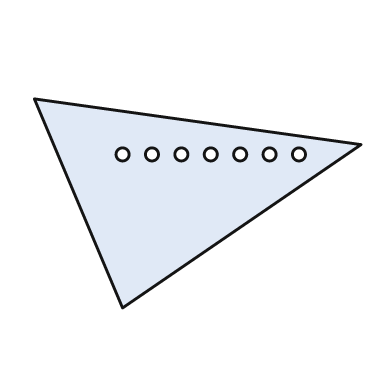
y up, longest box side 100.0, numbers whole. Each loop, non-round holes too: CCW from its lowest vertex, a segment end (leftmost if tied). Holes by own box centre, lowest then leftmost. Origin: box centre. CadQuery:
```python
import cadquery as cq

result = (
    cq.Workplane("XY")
    .moveTo(-23.0, -32.0)
    .lineTo(50.0, 18.0)
    .lineTo(-50.0, 32.0)
    .close()
    .moveTo(-23.0, 15.0)
    .circle(2.0)
    .moveTo(-14.0, 15.0)
    .circle(2.0)
    .moveTo(-5.0, 15.0)
    .circle(2.0)
    .moveTo(4.0, 15.0)
    .circle(2.0)
    .moveTo(13.0, 15.0)
    .circle(2.0)
    .moveTo(22.0, 15.0)
    .circle(2.0)
    .moveTo(31.0, 15.0)
    .circle(2.0)
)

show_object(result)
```